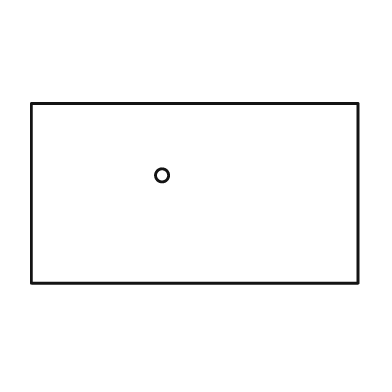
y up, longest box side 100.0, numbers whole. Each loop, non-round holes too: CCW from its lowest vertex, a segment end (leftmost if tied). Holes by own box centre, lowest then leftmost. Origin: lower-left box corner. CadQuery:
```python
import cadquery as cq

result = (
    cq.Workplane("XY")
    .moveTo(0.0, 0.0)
    .lineTo(100.0, 0.0)
    .lineTo(100.0, 55.0)
    .lineTo(0.0, 55.0)
    .close()
    .moveTo(40.0, 33.0)
    .circle(2.0)
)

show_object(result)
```